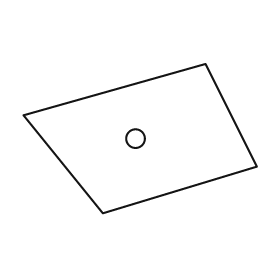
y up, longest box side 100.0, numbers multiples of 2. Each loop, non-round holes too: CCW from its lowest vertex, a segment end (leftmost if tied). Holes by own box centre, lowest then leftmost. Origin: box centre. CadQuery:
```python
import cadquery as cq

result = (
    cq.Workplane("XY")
    .moveTo(-16.0, -32.0)
    .lineTo(50.0, -12.0)
    .lineTo(28.0, 32.0)
    .lineTo(-50.0, 10.0)
    .close()
    .moveTo(-2.0, 0.0)
    .circle(4.0)
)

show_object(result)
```